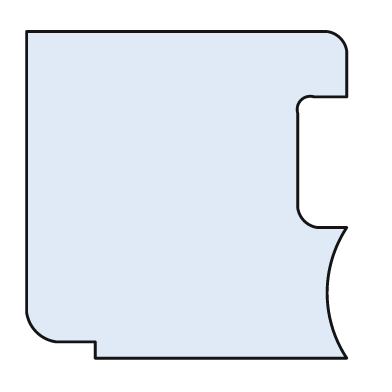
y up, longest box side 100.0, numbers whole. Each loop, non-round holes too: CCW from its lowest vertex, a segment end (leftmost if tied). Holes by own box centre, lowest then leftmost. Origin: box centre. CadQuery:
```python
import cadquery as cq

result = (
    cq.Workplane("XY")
    .moveTo(-28.0, -50.0)
    .lineTo(49.0, -50.0)
    .threePointArc((43.0, -30.0), (49.0, -10.0))
    .lineTo(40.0, -10.0)
    .threePointArc((36.0, -8.0), (34.0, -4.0))
    .lineTo(34.0, 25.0)
    .threePointArc((35.0, 29.0), (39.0, 30.0))
    .lineTo(49.0, 30.0)
    .lineTo(49.0, 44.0)
    .threePointArc((47.0, 48.0), (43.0, 50.0))
    .lineTo(-49.0, 50.0)
    .lineTo(-49.0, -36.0)
    .threePointArc((-46.0, -42.0), (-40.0, -45.0))
    .lineTo(-28.0, -45.0)
    .close()
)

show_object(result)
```